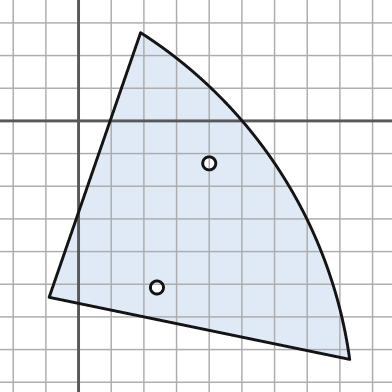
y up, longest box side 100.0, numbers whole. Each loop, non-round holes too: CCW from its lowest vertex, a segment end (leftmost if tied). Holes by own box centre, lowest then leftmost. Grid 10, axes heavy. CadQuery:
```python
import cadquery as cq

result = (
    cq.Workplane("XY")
    .moveTo(83.0, -73.0)
    .threePointArc((62.0, -16.0), (19.0, 27.0))
    .lineTo(-9.0, -54.0)
    .close()
    .moveTo(24.0, -51.0)
    .circle(2.0)
    .moveTo(40.0, -13.0)
    .circle(2.0)
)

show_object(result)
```